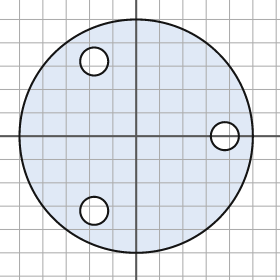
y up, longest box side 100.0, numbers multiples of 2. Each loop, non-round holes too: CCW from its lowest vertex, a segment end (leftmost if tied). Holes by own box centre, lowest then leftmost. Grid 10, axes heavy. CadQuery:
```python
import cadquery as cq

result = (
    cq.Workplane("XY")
    .moveTo(0.0, 0.0)
    .circle(50.0)
    .moveTo(-18.0, -32.0)
    .circle(6.0)
    .moveTo(38.0, 0.0)
    .circle(6.0)
    .moveTo(-18.0, 32.0)
    .circle(6.0)
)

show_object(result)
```